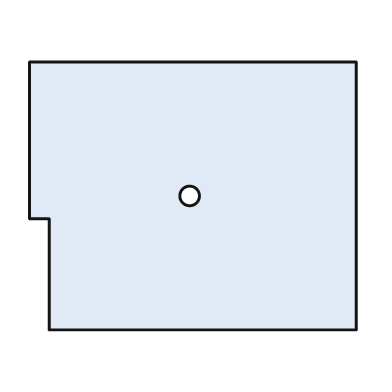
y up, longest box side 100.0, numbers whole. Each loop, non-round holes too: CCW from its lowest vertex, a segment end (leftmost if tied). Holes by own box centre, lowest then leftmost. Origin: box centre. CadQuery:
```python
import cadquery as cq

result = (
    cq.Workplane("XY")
    .moveTo(-44.0, -41.0)
    .lineTo(50.0, -41.0)
    .lineTo(50.0, 41.0)
    .lineTo(-50.0, 41.0)
    .lineTo(-50.0, -7.0)
    .lineTo(-44.0, -7.0)
    .close()
    .moveTo(-1.0, 0.0)
    .circle(3.0)
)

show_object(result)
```